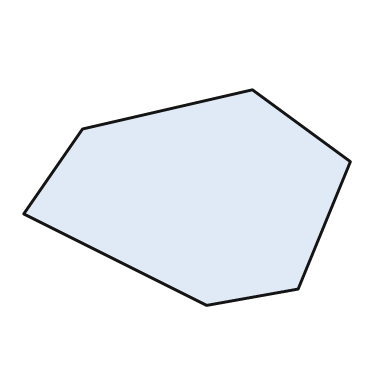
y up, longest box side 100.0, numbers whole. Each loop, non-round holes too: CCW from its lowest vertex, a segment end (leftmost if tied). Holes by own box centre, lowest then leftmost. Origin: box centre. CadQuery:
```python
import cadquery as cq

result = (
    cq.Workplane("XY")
    .moveTo(6.0, -33.0)
    .lineTo(34.0, -28.0)
    .lineTo(50.0, 11.0)
    .lineTo(20.0, 33.0)
    .lineTo(-32.0, 21.0)
    .lineTo(-50.0, -5.0)
    .close()
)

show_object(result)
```